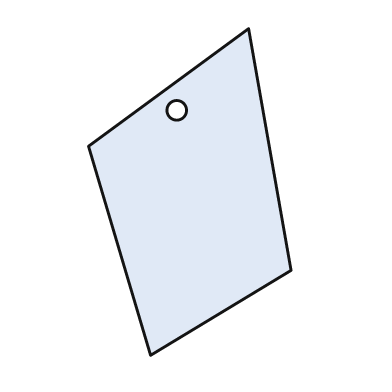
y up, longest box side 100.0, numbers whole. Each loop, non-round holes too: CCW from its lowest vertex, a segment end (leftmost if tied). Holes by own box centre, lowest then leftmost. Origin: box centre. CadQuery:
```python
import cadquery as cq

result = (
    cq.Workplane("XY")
    .moveTo(-12.0, -50.0)
    .lineTo(31.0, -24.0)
    .lineTo(18.0, 50.0)
    .lineTo(-31.0, 14.0)
    .close()
    .moveTo(-4.0, 25.0)
    .circle(3.0)
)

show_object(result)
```